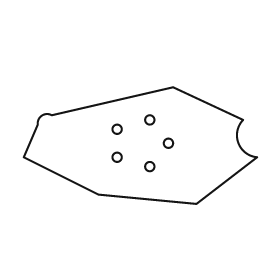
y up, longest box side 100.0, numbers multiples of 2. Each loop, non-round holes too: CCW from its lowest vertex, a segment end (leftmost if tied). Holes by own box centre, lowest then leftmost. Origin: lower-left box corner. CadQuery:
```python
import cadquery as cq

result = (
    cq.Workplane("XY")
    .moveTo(74.0, 0.0)
    .lineTo(100.0, 20.0)
    .threePointArc((92.0, 26.0), (94.0, 36.0))
    .lineTo(64.0, 50.0)
    .lineTo(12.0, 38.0)
    .threePointArc((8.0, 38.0), (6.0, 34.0))
    .lineTo(0.0, 20.0)
    .lineTo(32.0, 4.0)
    .close()
    .moveTo(54.0, 16.0)
    .circle(2.0)
    .moveTo(40.0, 20.0)
    .circle(2.0)
    .moveTo(62.0, 26.0)
    .circle(2.0)
    .moveTo(40.0, 32.0)
    .circle(2.0)
    .moveTo(54.0, 36.0)
    .circle(2.0)
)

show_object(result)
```